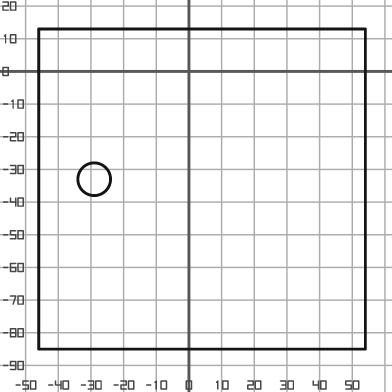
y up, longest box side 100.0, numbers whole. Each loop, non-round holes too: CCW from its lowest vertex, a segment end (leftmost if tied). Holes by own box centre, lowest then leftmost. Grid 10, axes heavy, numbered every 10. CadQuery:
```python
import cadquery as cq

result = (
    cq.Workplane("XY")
    .moveTo(-46.0, -85.0)
    .lineTo(54.0, -85.0)
    .lineTo(54.0, 13.0)
    .lineTo(-46.0, 13.0)
    .close()
    .moveTo(-29.0, -33.0)
    .circle(5.0)
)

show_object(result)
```